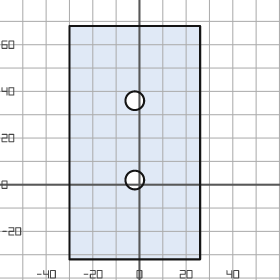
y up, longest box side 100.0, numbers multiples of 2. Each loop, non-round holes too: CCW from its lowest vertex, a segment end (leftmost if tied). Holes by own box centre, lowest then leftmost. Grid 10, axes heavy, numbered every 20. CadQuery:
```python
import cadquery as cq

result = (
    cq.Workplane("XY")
    .moveTo(-30.0, -32.0)
    .lineTo(26.0, -32.0)
    .lineTo(26.0, 68.0)
    .lineTo(-30.0, 68.0)
    .close()
    .moveTo(-2.0, 2.0)
    .circle(4.0)
    .moveTo(-2.0, 36.0)
    .circle(4.0)
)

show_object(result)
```